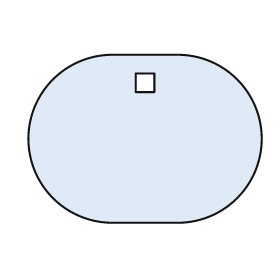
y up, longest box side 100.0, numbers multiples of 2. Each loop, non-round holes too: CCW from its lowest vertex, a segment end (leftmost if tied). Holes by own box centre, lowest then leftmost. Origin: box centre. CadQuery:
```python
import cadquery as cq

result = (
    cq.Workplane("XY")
    .moveTo(-14.0, -36.0)
    .lineTo(14.0, -36.0)
    .threePointArc((50.0, 0.0), (14.0, 36.0))
    .lineTo(-14.0, 36.0)
    .threePointArc((-50.0, 0.0), (-14.0, -36.0))
    .close()
    .moveTo(-4.0, 20.0)
    .lineTo(4.0, 20.0)
    .lineTo(4.0, 28.0)
    .lineTo(-4.0, 28.0)
    .close()
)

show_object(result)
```